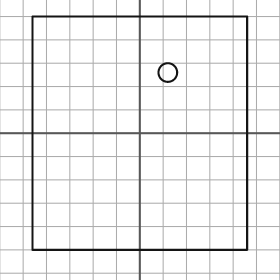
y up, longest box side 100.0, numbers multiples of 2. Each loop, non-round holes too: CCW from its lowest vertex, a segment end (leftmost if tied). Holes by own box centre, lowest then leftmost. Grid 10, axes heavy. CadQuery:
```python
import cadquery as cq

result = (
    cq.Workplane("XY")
    .moveTo(-46.0, -50.0)
    .lineTo(46.0, -50.0)
    .lineTo(46.0, 50.0)
    .lineTo(-46.0, 50.0)
    .close()
    .moveTo(12.0, 26.0)
    .circle(4.0)
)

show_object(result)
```